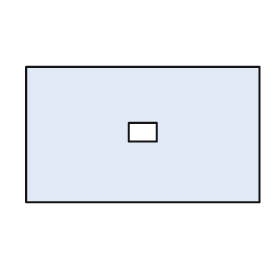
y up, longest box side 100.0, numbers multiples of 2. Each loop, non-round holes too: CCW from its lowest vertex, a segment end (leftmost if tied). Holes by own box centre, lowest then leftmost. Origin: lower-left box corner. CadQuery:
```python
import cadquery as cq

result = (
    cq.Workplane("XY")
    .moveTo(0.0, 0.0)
    .lineTo(100.0, 0.0)
    .lineTo(100.0, 58.0)
    .lineTo(0.0, 58.0)
    .close()
    .moveTo(44.0, 26.0)
    .lineTo(56.0, 26.0)
    .lineTo(56.0, 34.0)
    .lineTo(44.0, 34.0)
    .close()
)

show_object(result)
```